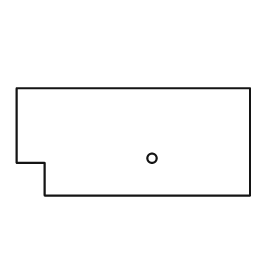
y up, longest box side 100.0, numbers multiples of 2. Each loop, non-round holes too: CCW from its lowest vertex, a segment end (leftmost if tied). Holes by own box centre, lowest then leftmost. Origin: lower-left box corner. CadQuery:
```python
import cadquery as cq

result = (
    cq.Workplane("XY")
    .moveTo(12.0, 0.0)
    .lineTo(100.0, 0.0)
    .lineTo(100.0, 46.0)
    .lineTo(0.0, 46.0)
    .lineTo(0.0, 14.0)
    .lineTo(12.0, 14.0)
    .close()
    .moveTo(58.0, 16.0)
    .circle(2.0)
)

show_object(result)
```